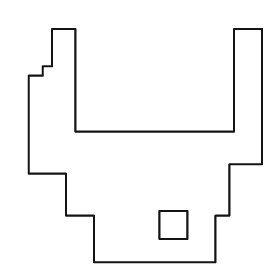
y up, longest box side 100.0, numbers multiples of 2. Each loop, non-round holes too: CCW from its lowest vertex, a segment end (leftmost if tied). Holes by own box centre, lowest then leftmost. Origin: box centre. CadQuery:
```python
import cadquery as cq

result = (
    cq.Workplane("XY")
    .moveTo(-22.0, -50.0)
    .lineTo(30.0, -50.0)
    .lineTo(30.0, -30.0)
    .lineTo(36.0, -30.0)
    .lineTo(36.0, -8.0)
    .lineTo(50.0, -8.0)
    .lineTo(50.0, 50.0)
    .lineTo(38.0, 50.0)
    .lineTo(38.0, 6.0)
    .lineTo(-30.0, 6.0)
    .lineTo(-30.0, 50.0)
    .lineTo(-40.0, 50.0)
    .lineTo(-40.0, 34.0)
    .lineTo(-44.0, 34.0)
    .lineTo(-44.0, 30.0)
    .lineTo(-50.0, 30.0)
    .lineTo(-50.0, -12.0)
    .lineTo(-34.0, -12.0)
    .lineTo(-34.0, -30.0)
    .lineTo(-22.0, -30.0)
    .close()
    .moveTo(6.0, -40.0)
    .lineTo(18.0, -40.0)
    .lineTo(18.0, -28.0)
    .lineTo(6.0, -28.0)
    .close()
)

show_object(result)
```